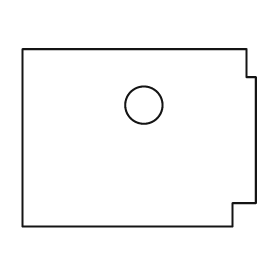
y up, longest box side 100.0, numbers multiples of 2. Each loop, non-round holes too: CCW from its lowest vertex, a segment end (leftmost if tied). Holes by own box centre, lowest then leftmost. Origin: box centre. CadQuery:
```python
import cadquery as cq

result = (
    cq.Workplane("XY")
    .moveTo(-50.0, -38.0)
    .lineTo(40.0, -38.0)
    .lineTo(40.0, -28.0)
    .lineTo(50.0, -28.0)
    .lineTo(50.0, 26.0)
    .lineTo(46.0, 26.0)
    .lineTo(46.0, 38.0)
    .lineTo(-50.0, 38.0)
    .close()
    .moveTo(2.0, 14.0)
    .circle(8.0)
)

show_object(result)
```